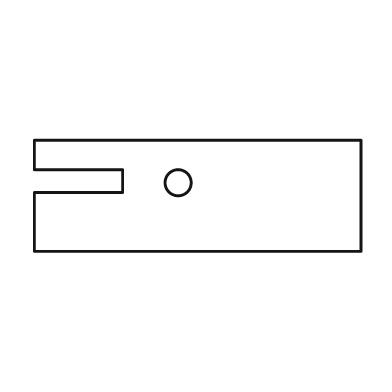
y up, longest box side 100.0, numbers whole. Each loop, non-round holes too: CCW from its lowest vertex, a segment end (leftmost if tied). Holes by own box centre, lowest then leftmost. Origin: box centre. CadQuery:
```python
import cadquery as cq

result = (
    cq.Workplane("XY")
    .moveTo(-50.0, -17.0)
    .lineTo(50.0, -17.0)
    .lineTo(50.0, 17.0)
    .lineTo(-50.0, 17.0)
    .lineTo(-50.0, 8.0)
    .lineTo(-23.0, 8.0)
    .lineTo(-23.0, 1.0)
    .lineTo(-50.0, 1.0)
    .close()
    .moveTo(-6.0, 4.0)
    .circle(4.0)
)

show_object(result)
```